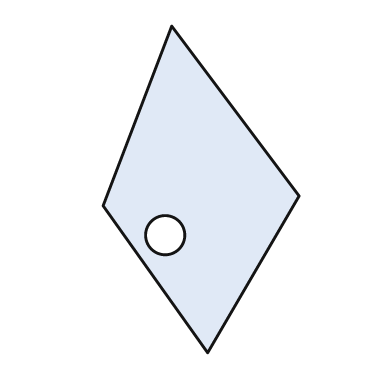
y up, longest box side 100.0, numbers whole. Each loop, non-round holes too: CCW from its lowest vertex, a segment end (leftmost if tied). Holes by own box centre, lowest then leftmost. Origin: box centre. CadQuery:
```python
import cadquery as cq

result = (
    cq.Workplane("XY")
    .moveTo(2.0, -50.0)
    .lineTo(30.0, -2.0)
    .lineTo(-9.0, 50.0)
    .lineTo(-30.0, -5.0)
    .close()
    .moveTo(-11.0, -14.0)
    .circle(6.0)
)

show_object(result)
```